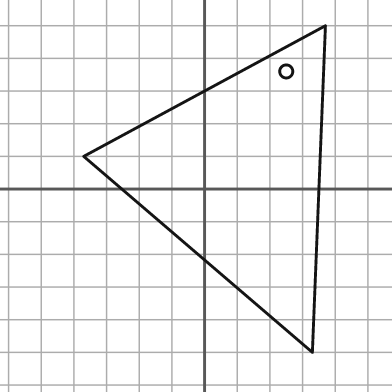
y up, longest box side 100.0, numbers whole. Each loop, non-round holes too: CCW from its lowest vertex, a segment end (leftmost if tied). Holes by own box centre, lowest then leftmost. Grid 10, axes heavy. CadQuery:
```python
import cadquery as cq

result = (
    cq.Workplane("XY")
    .moveTo(33.0, -50.0)
    .lineTo(37.0, 50.0)
    .lineTo(-37.0, 10.0)
    .close()
    .moveTo(25.0, 36.0)
    .circle(2.0)
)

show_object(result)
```